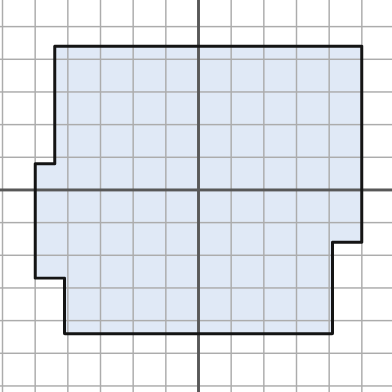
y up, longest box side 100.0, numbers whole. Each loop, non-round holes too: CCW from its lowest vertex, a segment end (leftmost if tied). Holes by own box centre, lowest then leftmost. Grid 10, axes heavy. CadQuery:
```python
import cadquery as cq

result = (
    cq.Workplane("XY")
    .moveTo(-41.0, -44.0)
    .lineTo(41.0, -44.0)
    .lineTo(41.0, -16.0)
    .lineTo(50.0, -16.0)
    .lineTo(50.0, 44.0)
    .lineTo(-44.0, 44.0)
    .lineTo(-44.0, 8.0)
    .lineTo(-50.0, 8.0)
    .lineTo(-50.0, -27.0)
    .lineTo(-41.0, -27.0)
    .close()
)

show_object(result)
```